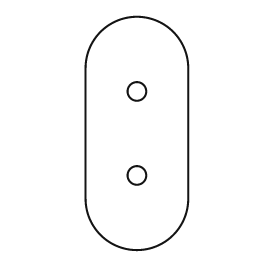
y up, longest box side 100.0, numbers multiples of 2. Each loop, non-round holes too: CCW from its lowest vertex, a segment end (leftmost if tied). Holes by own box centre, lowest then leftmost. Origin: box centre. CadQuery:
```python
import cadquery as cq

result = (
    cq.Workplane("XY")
    .moveTo(-22.0, -28.0)
    .threePointArc((0.0, -50.0), (22.0, -28.0))
    .lineTo(22.0, 28.0)
    .threePointArc((0.0, 50.0), (-22.0, 28.0))
    .close()
    .moveTo(0.0, -18.0)
    .circle(4.0)
    .moveTo(0.0, 18.0)
    .circle(4.0)
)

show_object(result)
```